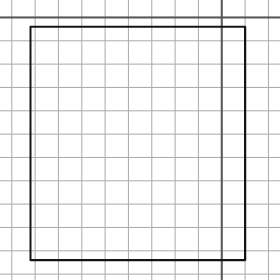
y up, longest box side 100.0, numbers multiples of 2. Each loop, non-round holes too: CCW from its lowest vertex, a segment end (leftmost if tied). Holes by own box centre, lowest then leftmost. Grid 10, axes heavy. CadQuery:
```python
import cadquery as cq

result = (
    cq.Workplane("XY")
    .moveTo(-82.0, -104.0)
    .lineTo(10.0, -104.0)
    .lineTo(10.0, -4.0)
    .lineTo(-82.0, -4.0)
    .close()
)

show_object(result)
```